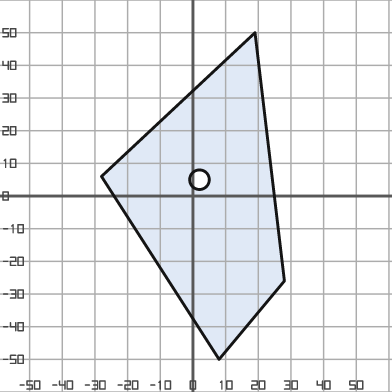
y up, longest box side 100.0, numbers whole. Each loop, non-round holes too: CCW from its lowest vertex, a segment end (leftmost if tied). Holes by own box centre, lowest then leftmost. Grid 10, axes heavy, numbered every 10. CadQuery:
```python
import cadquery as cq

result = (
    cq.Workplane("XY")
    .moveTo(8.0, -50.0)
    .lineTo(28.0, -26.0)
    .lineTo(19.0, 50.0)
    .lineTo(-28.0, 6.0)
    .close()
    .moveTo(2.0, 5.0)
    .circle(3.0)
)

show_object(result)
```